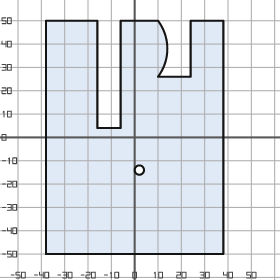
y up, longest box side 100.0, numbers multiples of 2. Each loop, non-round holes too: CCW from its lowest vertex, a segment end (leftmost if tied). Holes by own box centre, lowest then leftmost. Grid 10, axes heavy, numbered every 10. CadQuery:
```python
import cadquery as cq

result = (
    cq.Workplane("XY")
    .moveTo(-38.0, -50.0)
    .lineTo(38.0, -50.0)
    .lineTo(38.0, 50.0)
    .lineTo(24.0, 50.0)
    .lineTo(24.0, 26.0)
    .lineTo(10.0, 26.0)
    .threePointArc((14.0, 38.0), (10.0, 50.0))
    .lineTo(-6.0, 50.0)
    .lineTo(-6.0, 4.0)
    .lineTo(-16.0, 4.0)
    .lineTo(-16.0, 50.0)
    .lineTo(-38.0, 50.0)
    .close()
    .moveTo(2.0, -14.0)
    .circle(2.0)
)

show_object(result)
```